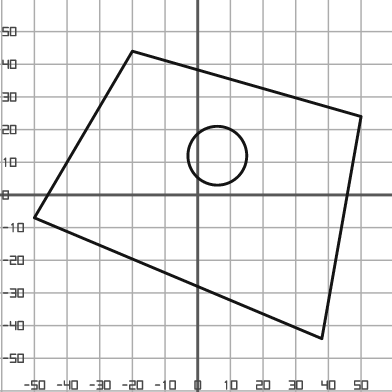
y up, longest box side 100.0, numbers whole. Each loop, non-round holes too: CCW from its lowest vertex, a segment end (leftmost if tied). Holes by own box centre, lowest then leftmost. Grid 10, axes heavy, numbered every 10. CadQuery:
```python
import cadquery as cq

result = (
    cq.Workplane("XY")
    .moveTo(38.0, -44.0)
    .lineTo(50.0, 24.0)
    .lineTo(-20.0, 44.0)
    .lineTo(-50.0, -7.0)
    .close()
    .moveTo(6.0, 12.0)
    .circle(9.0)
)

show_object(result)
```